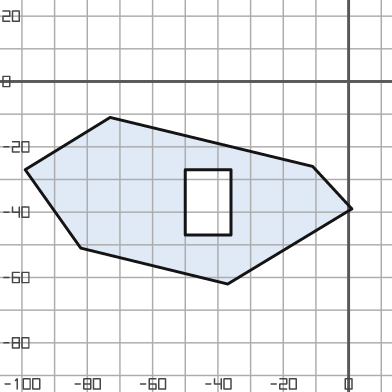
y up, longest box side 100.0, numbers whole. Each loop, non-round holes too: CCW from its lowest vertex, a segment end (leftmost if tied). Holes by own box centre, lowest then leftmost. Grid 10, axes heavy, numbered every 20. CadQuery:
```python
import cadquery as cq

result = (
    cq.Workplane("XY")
    .moveTo(-37.0, -62.0)
    .lineTo(1.0, -39.0)
    .lineTo(-11.0, -26.0)
    .lineTo(-73.0, -11.0)
    .lineTo(-99.0, -27.0)
    .lineTo(-82.0, -51.0)
    .close()
    .moveTo(-50.0, -47.0)
    .lineTo(-36.0, -47.0)
    .lineTo(-36.0, -27.0)
    .lineTo(-50.0, -27.0)
    .close()
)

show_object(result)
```